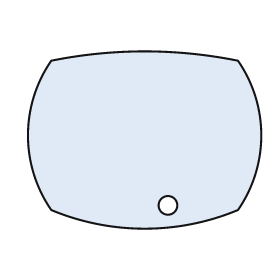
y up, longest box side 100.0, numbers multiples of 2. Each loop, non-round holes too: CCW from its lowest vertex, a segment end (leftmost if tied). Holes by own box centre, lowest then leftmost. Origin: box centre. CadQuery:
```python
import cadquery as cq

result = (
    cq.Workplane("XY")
    .moveTo(-40.0, -30.0)
    .threePointArc((0.0, -38.0), (40.0, -30.0))
    .threePointArc((50.0, 2.0), (40.0, 34.0))
    .threePointArc((0.0, 38.0), (-40.0, 34.0))
    .threePointArc((-50.0, 2.0), (-40.0, -30.0))
    .close()
    .moveTo(10.0, -28.0)
    .circle(4.0)
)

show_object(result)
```